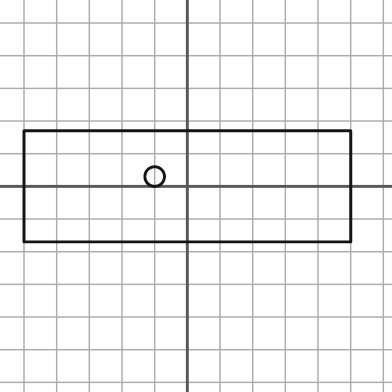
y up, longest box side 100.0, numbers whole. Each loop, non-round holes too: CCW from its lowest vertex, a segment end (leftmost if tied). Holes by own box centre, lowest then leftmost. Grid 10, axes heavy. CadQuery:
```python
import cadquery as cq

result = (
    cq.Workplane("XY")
    .moveTo(-50.0, -17.0)
    .lineTo(50.0, -17.0)
    .lineTo(50.0, 17.0)
    .lineTo(-50.0, 17.0)
    .close()
    .moveTo(-10.0, 3.0)
    .circle(3.0)
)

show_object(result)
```